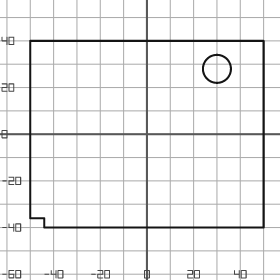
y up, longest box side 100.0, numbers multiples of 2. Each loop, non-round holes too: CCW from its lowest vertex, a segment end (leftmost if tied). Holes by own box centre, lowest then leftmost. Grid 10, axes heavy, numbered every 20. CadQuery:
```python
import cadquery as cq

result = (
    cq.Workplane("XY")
    .moveTo(-44.0, -40.0)
    .lineTo(50.0, -40.0)
    .lineTo(50.0, 40.0)
    .lineTo(-50.0, 40.0)
    .lineTo(-50.0, -36.0)
    .lineTo(-44.0, -36.0)
    .close()
    .moveTo(30.0, 28.0)
    .circle(6.0)
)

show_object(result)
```